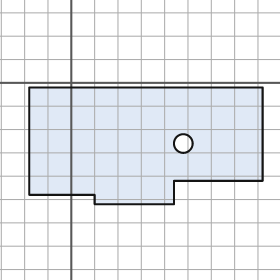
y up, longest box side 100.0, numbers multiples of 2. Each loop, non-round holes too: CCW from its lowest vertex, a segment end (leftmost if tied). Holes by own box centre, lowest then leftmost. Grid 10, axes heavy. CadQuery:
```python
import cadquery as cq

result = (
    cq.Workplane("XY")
    .moveTo(10.0, -52.0)
    .lineTo(44.0, -52.0)
    .lineTo(44.0, -42.0)
    .lineTo(82.0, -42.0)
    .lineTo(82.0, -2.0)
    .lineTo(-18.0, -2.0)
    .lineTo(-18.0, -48.0)
    .lineTo(10.0, -48.0)
    .close()
    .moveTo(48.0, -26.0)
    .circle(4.0)
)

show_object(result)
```